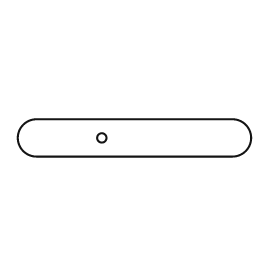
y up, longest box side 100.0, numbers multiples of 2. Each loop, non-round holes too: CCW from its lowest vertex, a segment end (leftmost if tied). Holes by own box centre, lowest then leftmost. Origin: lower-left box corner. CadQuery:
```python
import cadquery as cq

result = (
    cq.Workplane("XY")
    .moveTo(8.0, 0.0)
    .lineTo(92.0, 0.0)
    .threePointArc((100.0, 8.0), (92.0, 16.0))
    .lineTo(8.0, 16.0)
    .threePointArc((0.0, 8.0), (8.0, 0.0))
    .close()
    .moveTo(36.0, 8.0)
    .circle(2.0)
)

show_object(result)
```